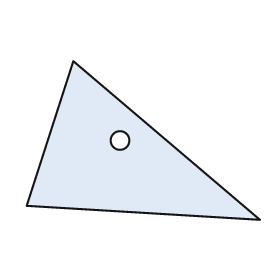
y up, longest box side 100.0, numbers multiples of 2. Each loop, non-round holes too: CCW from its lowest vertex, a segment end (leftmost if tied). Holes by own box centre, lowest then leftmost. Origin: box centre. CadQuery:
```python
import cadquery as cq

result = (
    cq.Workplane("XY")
    .moveTo(50.0, -34.0)
    .lineTo(-30.0, 34.0)
    .lineTo(-50.0, -28.0)
    .close()
    .moveTo(-10.0, 0.0)
    .circle(4.0)
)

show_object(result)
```